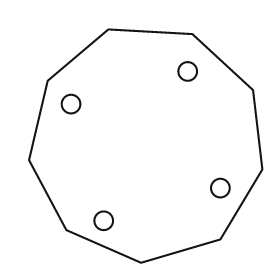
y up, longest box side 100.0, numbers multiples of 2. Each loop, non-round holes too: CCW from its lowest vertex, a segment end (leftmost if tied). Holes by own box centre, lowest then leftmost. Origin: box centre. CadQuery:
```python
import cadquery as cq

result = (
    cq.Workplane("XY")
    .moveTo(-2.0, -50.0)
    .lineTo(32.0, -40.0)
    .lineTo(50.0, -10.0)
    .lineTo(46.0, 24.0)
    .lineTo(20.0, 48.0)
    .lineTo(-16.0, 50.0)
    .lineTo(-42.0, 28.0)
    .lineTo(-50.0, -6.0)
    .lineTo(-34.0, -36.0)
    .close()
    .moveTo(-18.0, -32.0)
    .circle(4.0)
    .moveTo(32.0, -18.0)
    .circle(4.0)
    .moveTo(-32.0, 18.0)
    .circle(4.0)
    .moveTo(18.0, 32.0)
    .circle(4.0)
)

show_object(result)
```